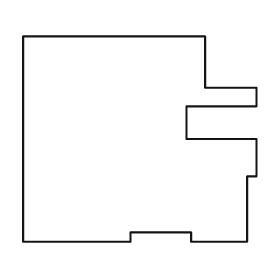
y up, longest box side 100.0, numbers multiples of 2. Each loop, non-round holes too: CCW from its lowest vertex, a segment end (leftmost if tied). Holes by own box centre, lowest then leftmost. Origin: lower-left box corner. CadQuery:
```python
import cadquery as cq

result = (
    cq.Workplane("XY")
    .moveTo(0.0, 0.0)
    .lineTo(46.0, 0.0)
    .lineTo(46.0, 4.0)
    .lineTo(72.0, 4.0)
    .lineTo(72.0, 0.0)
    .lineTo(96.0, 0.0)
    .lineTo(96.0, 28.0)
    .lineTo(100.0, 28.0)
    .lineTo(100.0, 44.0)
    .lineTo(70.0, 44.0)
    .lineTo(70.0, 58.0)
    .lineTo(100.0, 58.0)
    .lineTo(100.0, 66.0)
    .lineTo(78.0, 66.0)
    .lineTo(78.0, 88.0)
    .lineTo(0.0, 88.0)
    .close()
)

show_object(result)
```